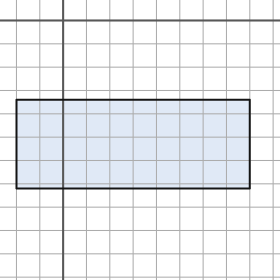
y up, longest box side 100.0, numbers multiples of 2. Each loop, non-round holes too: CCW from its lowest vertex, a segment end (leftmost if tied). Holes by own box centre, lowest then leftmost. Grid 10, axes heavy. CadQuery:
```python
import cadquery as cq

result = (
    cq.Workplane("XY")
    .moveTo(-20.0, -72.0)
    .lineTo(80.0, -72.0)
    .lineTo(80.0, -34.0)
    .lineTo(-20.0, -34.0)
    .close()
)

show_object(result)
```